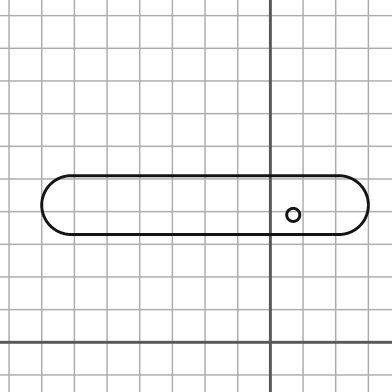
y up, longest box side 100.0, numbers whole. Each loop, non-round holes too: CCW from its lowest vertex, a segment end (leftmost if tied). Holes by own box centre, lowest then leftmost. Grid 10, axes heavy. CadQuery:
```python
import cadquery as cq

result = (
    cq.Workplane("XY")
    .moveTo(-61.0, 33.0)
    .lineTo(21.0, 33.0)
    .threePointArc((30.0, 42.0), (21.0, 51.0))
    .lineTo(-61.0, 51.0)
    .threePointArc((-70.0, 42.0), (-61.0, 33.0))
    .close()
    .moveTo(7.0, 39.0)
    .circle(2.0)
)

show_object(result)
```